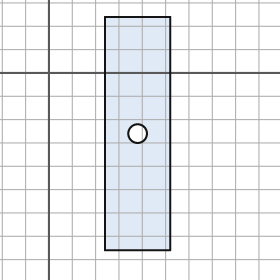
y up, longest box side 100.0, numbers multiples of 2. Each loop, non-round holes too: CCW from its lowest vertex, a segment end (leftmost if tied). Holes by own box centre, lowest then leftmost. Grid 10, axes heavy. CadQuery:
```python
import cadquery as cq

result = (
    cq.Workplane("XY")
    .moveTo(24.0, -76.0)
    .lineTo(52.0, -76.0)
    .lineTo(52.0, 24.0)
    .lineTo(24.0, 24.0)
    .close()
    .moveTo(38.0, -26.0)
    .circle(4.0)
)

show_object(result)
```